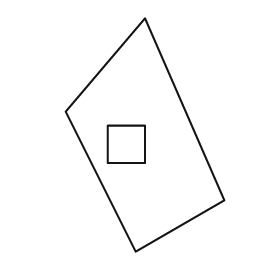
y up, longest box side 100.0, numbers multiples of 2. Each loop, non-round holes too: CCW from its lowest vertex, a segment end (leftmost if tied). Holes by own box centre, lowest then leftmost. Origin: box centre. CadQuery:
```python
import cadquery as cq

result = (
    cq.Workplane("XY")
    .moveTo(-4.0, -50.0)
    .lineTo(34.0, -28.0)
    .lineTo(0.0, 50.0)
    .lineTo(-34.0, 10.0)
    .close()
    .moveTo(-16.0, -12.0)
    .lineTo(0.0, -12.0)
    .lineTo(0.0, 4.0)
    .lineTo(-16.0, 4.0)
    .close()
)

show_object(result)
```